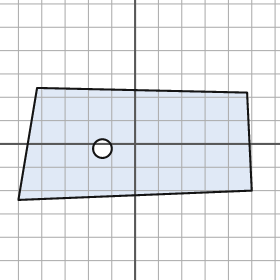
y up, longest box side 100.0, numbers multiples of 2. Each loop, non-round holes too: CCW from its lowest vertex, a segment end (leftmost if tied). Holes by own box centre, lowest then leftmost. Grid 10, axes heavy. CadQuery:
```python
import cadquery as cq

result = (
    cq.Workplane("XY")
    .moveTo(-50.0, -24.0)
    .lineTo(50.0, -20.0)
    .lineTo(48.0, 22.0)
    .lineTo(-42.0, 24.0)
    .close()
    .moveTo(-14.0, -2.0)
    .circle(4.0)
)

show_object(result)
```